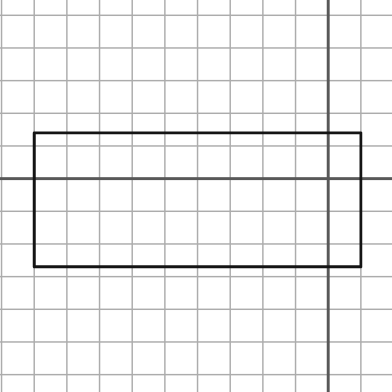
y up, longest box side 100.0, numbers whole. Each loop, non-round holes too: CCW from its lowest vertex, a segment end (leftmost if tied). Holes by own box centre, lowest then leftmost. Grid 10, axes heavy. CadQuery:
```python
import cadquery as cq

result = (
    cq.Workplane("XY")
    .moveTo(-90.0, -27.0)
    .lineTo(10.0, -27.0)
    .lineTo(10.0, 14.0)
    .lineTo(-90.0, 14.0)
    .close()
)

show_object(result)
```